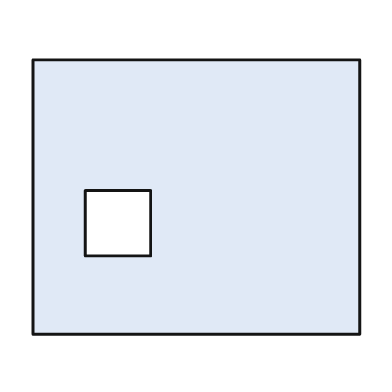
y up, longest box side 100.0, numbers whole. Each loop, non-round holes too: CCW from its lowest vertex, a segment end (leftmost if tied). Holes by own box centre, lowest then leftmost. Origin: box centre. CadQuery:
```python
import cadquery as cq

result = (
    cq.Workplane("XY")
    .moveTo(-50.0, -42.0)
    .lineTo(50.0, -42.0)
    .lineTo(50.0, 42.0)
    .lineTo(-50.0, 42.0)
    .close()
    .moveTo(-34.0, -18.0)
    .lineTo(-14.0, -18.0)
    .lineTo(-14.0, 2.0)
    .lineTo(-34.0, 2.0)
    .close()
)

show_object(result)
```